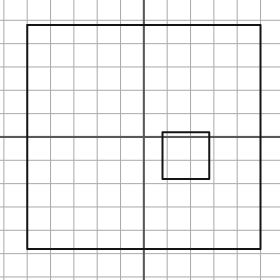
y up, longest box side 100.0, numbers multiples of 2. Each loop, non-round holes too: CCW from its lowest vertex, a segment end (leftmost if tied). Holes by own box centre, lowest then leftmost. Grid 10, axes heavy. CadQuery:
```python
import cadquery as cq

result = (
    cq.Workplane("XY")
    .moveTo(-50.0, -48.0)
    .lineTo(50.0, -48.0)
    .lineTo(50.0, 48.0)
    .lineTo(-50.0, 48.0)
    .close()
    .moveTo(8.0, -18.0)
    .lineTo(28.0, -18.0)
    .lineTo(28.0, 2.0)
    .lineTo(8.0, 2.0)
    .close()
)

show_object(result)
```